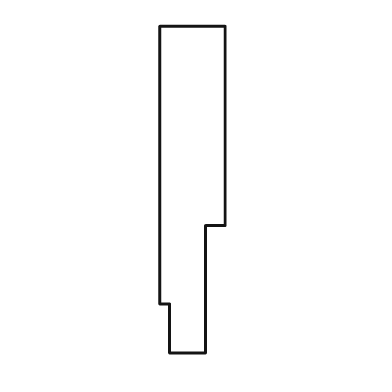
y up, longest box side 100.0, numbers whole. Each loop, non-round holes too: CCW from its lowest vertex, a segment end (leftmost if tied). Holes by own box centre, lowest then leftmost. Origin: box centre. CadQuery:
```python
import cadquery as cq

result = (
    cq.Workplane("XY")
    .moveTo(-7.0, -50.0)
    .lineTo(4.0, -50.0)
    .lineTo(4.0, -11.0)
    .lineTo(10.0, -11.0)
    .lineTo(10.0, 50.0)
    .lineTo(-10.0, 50.0)
    .lineTo(-10.0, -35.0)
    .lineTo(-7.0, -35.0)
    .close()
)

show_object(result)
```